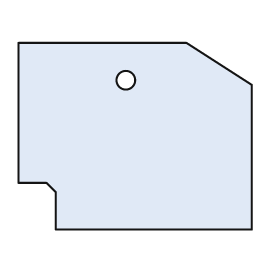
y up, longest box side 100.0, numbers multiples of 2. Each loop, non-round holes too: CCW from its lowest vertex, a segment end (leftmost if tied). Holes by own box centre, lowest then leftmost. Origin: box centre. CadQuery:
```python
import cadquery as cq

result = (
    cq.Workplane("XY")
    .moveTo(-34.0, -40.0)
    .lineTo(50.0, -40.0)
    .lineTo(50.0, 22.0)
    .lineTo(22.0, 40.0)
    .lineTo(-50.0, 40.0)
    .lineTo(-50.0, -20.0)
    .lineTo(-38.0, -20.0)
    .lineTo(-34.0, -24.0)
    .close()
    .moveTo(-4.0, 24.0)
    .circle(4.0)
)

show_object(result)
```